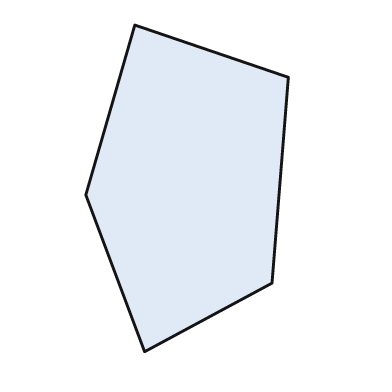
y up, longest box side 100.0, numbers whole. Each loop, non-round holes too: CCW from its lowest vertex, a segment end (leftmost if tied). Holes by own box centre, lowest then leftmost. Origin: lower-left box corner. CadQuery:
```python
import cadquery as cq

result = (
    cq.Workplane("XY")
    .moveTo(18.0, 0.0)
    .lineTo(57.0, 21.0)
    .lineTo(62.0, 84.0)
    .lineTo(15.0, 100.0)
    .lineTo(0.0, 48.0)
    .close()
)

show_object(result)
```